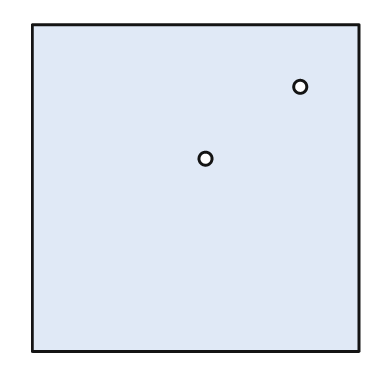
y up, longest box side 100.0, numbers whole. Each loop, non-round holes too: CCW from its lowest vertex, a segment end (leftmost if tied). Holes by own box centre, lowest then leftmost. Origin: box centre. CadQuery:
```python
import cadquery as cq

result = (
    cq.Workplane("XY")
    .moveTo(-50.0, -50.0)
    .lineTo(50.0, -50.0)
    .lineTo(50.0, 50.0)
    .lineTo(-50.0, 50.0)
    .close()
    .moveTo(3.0, 9.0)
    .circle(2.0)
    .moveTo(32.0, 31.0)
    .circle(2.0)
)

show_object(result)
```